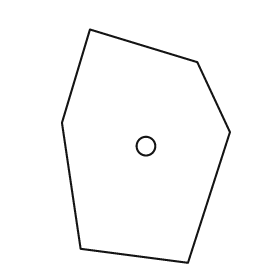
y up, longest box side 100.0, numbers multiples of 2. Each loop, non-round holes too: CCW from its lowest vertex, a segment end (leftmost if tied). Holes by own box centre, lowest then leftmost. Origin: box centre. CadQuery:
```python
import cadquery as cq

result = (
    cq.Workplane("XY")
    .moveTo(18.0, -50.0)
    .lineTo(36.0, 6.0)
    .lineTo(22.0, 36.0)
    .lineTo(-24.0, 50.0)
    .lineTo(-36.0, 10.0)
    .lineTo(-28.0, -44.0)
    .close()
    .moveTo(0.0, 0.0)
    .circle(4.0)
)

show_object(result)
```